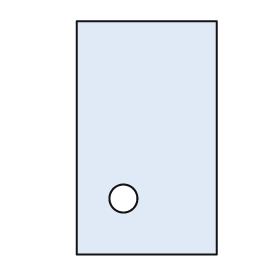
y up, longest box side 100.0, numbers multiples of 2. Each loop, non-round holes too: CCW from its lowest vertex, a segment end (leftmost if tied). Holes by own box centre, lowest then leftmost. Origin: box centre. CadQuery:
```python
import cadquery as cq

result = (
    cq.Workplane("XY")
    .moveTo(-30.0, -50.0)
    .lineTo(30.0, -50.0)
    .lineTo(30.0, 50.0)
    .lineTo(-30.0, 50.0)
    .close()
    .moveTo(-10.0, -26.0)
    .circle(6.0)
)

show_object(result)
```